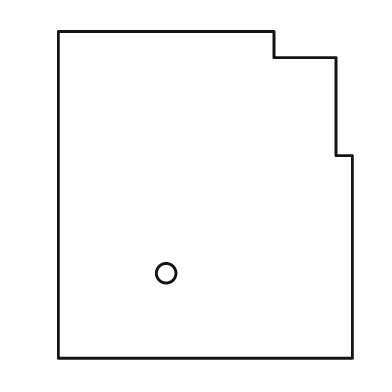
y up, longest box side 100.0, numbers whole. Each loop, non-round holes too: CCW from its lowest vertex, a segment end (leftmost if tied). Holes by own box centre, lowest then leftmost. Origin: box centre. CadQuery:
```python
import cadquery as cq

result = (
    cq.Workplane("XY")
    .moveTo(-45.0, -50.0)
    .lineTo(45.0, -50.0)
    .lineTo(45.0, 12.0)
    .lineTo(40.0, 12.0)
    .lineTo(40.0, 42.0)
    .lineTo(21.0, 42.0)
    .lineTo(21.0, 50.0)
    .lineTo(-45.0, 50.0)
    .close()
    .moveTo(-12.0, -24.0)
    .circle(3.0)
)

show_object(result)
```